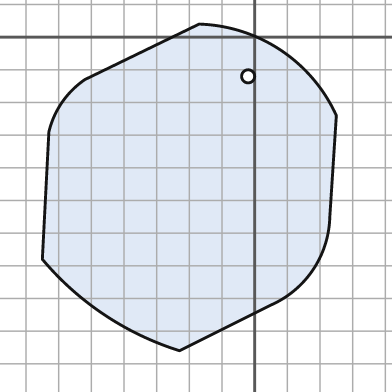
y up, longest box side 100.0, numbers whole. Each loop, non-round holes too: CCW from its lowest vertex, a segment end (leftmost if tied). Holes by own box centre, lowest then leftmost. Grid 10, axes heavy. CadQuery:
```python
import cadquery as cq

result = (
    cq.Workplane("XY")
    .moveTo(-23.0, -96.0)
    .lineTo(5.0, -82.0)
    .threePointArc((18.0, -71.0), (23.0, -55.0))
    .lineTo(25.0, -24.0)
    .threePointArc((8.0, -4.0), (-17.0, 4.0))
    .lineTo(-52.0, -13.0)
    .threePointArc((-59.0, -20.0), (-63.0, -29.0))
    .lineTo(-65.0, -68.0)
    .threePointArc((-46.0, -85.0), (-23.0, -96.0))
    .close()
    .moveTo(-2.0, -12.0)
    .circle(2.0)
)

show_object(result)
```